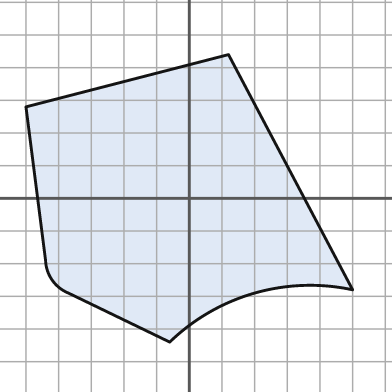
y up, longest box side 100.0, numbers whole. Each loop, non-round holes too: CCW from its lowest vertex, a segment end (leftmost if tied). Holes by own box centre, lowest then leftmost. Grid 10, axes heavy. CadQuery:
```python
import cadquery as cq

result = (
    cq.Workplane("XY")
    .moveTo(-6.0, -44.0)
    .threePointArc((20.0, -29.0), (50.0, -28.0))
    .lineTo(12.0, 44.0)
    .lineTo(-50.0, 28.0)
    .lineTo(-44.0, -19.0)
    .threePointArc((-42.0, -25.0), (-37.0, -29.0))
    .close()
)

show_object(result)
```